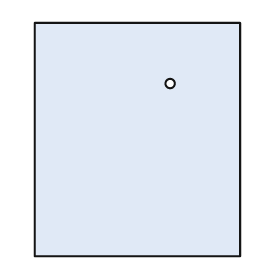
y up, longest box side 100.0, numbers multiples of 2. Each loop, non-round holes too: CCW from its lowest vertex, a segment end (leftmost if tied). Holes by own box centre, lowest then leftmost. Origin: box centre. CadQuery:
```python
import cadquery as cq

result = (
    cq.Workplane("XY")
    .moveTo(-44.0, -50.0)
    .lineTo(44.0, -50.0)
    .lineTo(44.0, 50.0)
    .lineTo(-44.0, 50.0)
    .close()
    .moveTo(14.0, 24.0)
    .circle(2.0)
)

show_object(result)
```